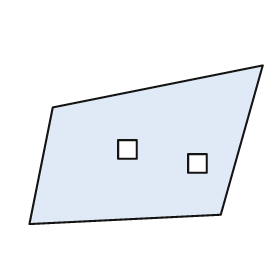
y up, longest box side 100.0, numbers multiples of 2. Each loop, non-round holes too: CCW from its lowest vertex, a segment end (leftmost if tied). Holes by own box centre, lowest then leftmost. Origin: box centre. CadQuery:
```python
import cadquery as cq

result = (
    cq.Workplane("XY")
    .moveTo(-50.0, -34.0)
    .lineTo(32.0, -30.0)
    .lineTo(50.0, 34.0)
    .lineTo(-40.0, 16.0)
    .close()
    .moveTo(18.0, -12.0)
    .lineTo(26.0, -12.0)
    .lineTo(26.0, -4.0)
    .lineTo(18.0, -4.0)
    .close()
    .moveTo(-12.0, -6.0)
    .lineTo(-4.0, -6.0)
    .lineTo(-4.0, 2.0)
    .lineTo(-12.0, 2.0)
    .close()
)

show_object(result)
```